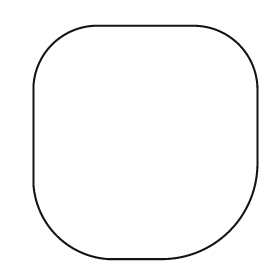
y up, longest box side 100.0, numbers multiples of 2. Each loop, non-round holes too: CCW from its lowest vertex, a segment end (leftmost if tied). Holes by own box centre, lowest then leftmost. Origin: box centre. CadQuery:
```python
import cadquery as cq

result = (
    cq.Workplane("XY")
    .moveTo(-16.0, -50.0)
    .lineTo(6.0, -50.0)
    .threePointArc((36.0, -38.0), (48.0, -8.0))
    .lineTo(48.0, 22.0)
    .threePointArc((40.0, 42.0), (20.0, 50.0))
    .lineTo(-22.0, 50.0)
    .threePointArc((-40.0, 42.0), (-48.0, 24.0))
    .lineTo(-48.0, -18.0)
    .threePointArc((-38.0, -40.0), (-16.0, -50.0))
    .close()
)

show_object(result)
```